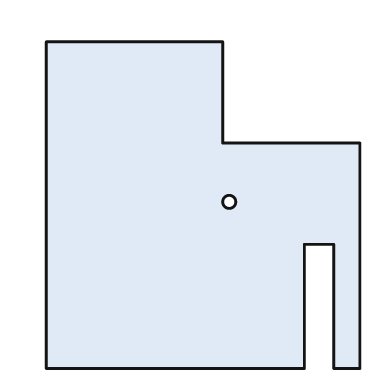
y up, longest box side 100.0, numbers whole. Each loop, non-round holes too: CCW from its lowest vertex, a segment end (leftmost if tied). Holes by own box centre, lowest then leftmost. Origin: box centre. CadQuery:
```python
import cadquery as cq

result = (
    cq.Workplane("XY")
    .moveTo(-48.0, -50.0)
    .lineTo(31.0, -50.0)
    .lineTo(31.0, -12.0)
    .lineTo(40.0, -12.0)
    .lineTo(40.0, -50.0)
    .lineTo(48.0, -50.0)
    .lineTo(48.0, 19.0)
    .lineTo(6.0, 19.0)
    .lineTo(6.0, 50.0)
    .lineTo(-48.0, 50.0)
    .close()
    .moveTo(8.0, 1.0)
    .circle(2.0)
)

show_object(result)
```